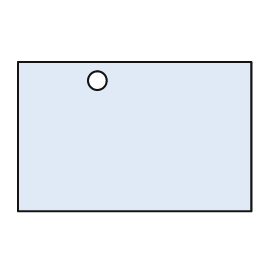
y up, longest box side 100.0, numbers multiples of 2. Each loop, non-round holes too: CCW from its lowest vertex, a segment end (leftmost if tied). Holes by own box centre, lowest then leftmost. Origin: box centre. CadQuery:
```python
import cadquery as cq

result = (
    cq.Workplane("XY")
    .moveTo(-50.0, -32.0)
    .lineTo(50.0, -32.0)
    .lineTo(50.0, 32.0)
    .lineTo(-50.0, 32.0)
    .close()
    .moveTo(-16.0, 24.0)
    .circle(4.0)
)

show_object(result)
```